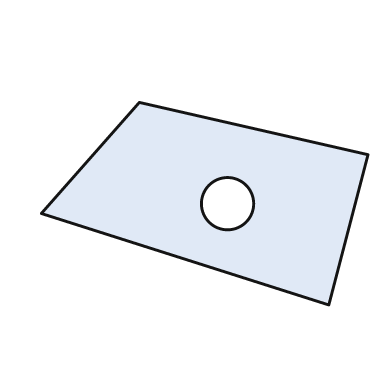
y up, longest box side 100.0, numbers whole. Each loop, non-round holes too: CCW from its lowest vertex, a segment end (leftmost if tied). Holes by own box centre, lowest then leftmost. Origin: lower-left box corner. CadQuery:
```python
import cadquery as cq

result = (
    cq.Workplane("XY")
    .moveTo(88.0, 0.0)
    .lineTo(100.0, 46.0)
    .lineTo(30.0, 62.0)
    .lineTo(0.0, 28.0)
    .close()
    .moveTo(57.0, 31.0)
    .circle(8.0)
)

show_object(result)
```